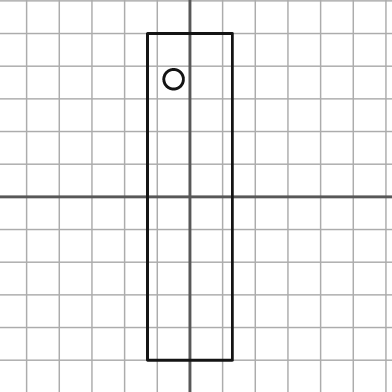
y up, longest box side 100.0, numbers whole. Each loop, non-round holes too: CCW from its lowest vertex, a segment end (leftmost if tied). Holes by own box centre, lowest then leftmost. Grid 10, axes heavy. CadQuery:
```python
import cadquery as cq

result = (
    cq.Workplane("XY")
    .moveTo(-13.0, -50.0)
    .lineTo(13.0, -50.0)
    .lineTo(13.0, 50.0)
    .lineTo(-13.0, 50.0)
    .close()
    .moveTo(-5.0, 36.0)
    .circle(3.0)
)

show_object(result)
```